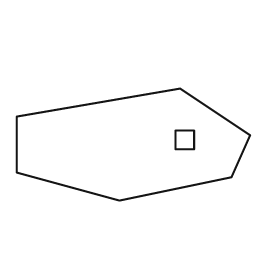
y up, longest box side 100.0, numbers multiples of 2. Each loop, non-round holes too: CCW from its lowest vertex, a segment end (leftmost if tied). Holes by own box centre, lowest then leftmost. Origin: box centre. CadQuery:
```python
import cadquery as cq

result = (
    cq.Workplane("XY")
    .moveTo(-6.0, -24.0)
    .lineTo(42.0, -14.0)
    .lineTo(50.0, 4.0)
    .lineTo(20.0, 24.0)
    .lineTo(-50.0, 12.0)
    .lineTo(-50.0, -12.0)
    .close()
    .moveTo(18.0, -2.0)
    .lineTo(26.0, -2.0)
    .lineTo(26.0, 6.0)
    .lineTo(18.0, 6.0)
    .close()
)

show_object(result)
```